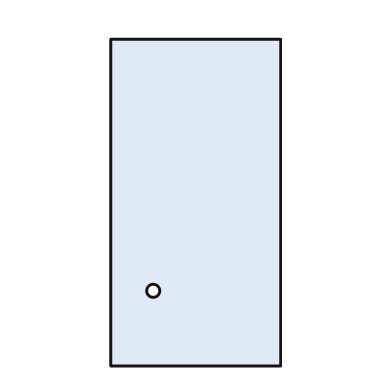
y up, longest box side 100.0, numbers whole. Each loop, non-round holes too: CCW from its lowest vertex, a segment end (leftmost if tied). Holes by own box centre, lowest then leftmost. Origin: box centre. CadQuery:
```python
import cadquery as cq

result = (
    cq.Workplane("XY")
    .moveTo(-26.0, -50.0)
    .lineTo(26.0, -50.0)
    .lineTo(26.0, 50.0)
    .lineTo(-26.0, 50.0)
    .close()
    .moveTo(-13.0, -27.0)
    .circle(2.0)
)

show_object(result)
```